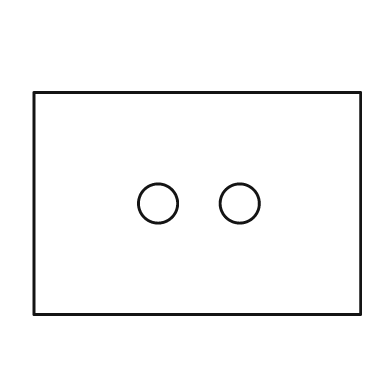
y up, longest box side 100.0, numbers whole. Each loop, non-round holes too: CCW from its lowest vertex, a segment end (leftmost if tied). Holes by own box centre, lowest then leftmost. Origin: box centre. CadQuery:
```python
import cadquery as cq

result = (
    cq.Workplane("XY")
    .moveTo(-50.0, -34.0)
    .lineTo(50.0, -34.0)
    .lineTo(50.0, 34.0)
    .lineTo(-50.0, 34.0)
    .close()
    .moveTo(-12.0, 0.0)
    .circle(6.0)
    .moveTo(13.0, 0.0)
    .circle(6.0)
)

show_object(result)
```